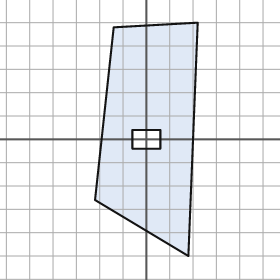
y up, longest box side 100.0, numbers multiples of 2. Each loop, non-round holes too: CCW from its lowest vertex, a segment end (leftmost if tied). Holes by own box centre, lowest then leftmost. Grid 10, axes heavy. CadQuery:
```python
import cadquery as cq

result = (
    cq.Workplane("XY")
    .moveTo(18.0, -50.0)
    .lineTo(22.0, 50.0)
    .lineTo(-14.0, 48.0)
    .lineTo(-22.0, -26.0)
    .close()
    .moveTo(-6.0, -4.0)
    .lineTo(6.0, -4.0)
    .lineTo(6.0, 4.0)
    .lineTo(-6.0, 4.0)
    .close()
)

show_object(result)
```